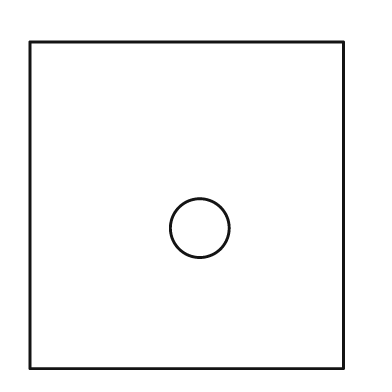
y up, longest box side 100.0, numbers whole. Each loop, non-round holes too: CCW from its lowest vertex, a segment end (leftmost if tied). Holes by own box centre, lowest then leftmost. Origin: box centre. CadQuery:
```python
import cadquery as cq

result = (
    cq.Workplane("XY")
    .moveTo(-48.0, -50.0)
    .lineTo(48.0, -50.0)
    .lineTo(48.0, 50.0)
    .lineTo(-48.0, 50.0)
    .close()
    .moveTo(4.0, -7.0)
    .circle(9.0)
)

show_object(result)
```